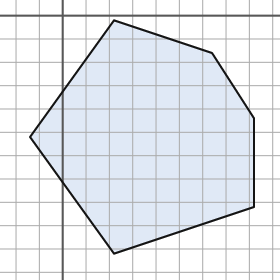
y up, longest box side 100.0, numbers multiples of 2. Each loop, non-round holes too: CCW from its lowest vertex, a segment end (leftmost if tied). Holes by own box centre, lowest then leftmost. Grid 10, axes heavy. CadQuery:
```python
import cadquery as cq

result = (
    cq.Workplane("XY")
    .moveTo(22.0, -102.0)
    .lineTo(82.0, -82.0)
    .lineTo(82.0, -44.0)
    .lineTo(64.0, -16.0)
    .lineTo(22.0, -2.0)
    .lineTo(-14.0, -52.0)
    .close()
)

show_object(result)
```